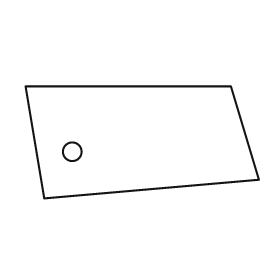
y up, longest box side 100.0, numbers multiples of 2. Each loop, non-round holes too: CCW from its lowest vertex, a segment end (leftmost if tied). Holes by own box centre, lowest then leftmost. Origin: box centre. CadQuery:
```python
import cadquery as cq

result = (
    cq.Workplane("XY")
    .moveTo(-42.0, -24.0)
    .lineTo(50.0, -16.0)
    .lineTo(38.0, 24.0)
    .lineTo(-50.0, 24.0)
    .close()
    .moveTo(-30.0, -4.0)
    .circle(4.0)
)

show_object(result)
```